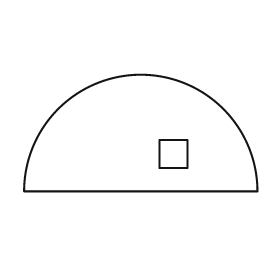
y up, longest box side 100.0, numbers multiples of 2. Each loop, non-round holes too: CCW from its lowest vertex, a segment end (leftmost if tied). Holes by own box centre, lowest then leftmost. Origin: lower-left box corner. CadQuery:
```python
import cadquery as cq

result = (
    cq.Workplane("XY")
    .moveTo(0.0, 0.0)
    .lineTo(100.0, 0.0)
    .threePointArc((50.0, 50.0), (0.0, 0.0))
    .close()
    .moveTo(58.0, 10.0)
    .lineTo(70.0, 10.0)
    .lineTo(70.0, 22.0)
    .lineTo(58.0, 22.0)
    .close()
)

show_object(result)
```